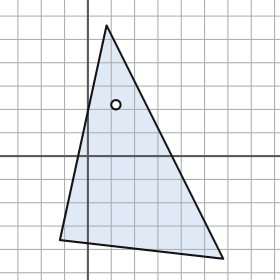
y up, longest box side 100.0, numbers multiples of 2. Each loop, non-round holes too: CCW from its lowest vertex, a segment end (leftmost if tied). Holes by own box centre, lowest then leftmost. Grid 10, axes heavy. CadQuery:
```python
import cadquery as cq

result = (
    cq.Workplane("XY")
    .moveTo(58.0, -44.0)
    .lineTo(8.0, 56.0)
    .lineTo(-12.0, -36.0)
    .close()
    .moveTo(12.0, 22.0)
    .circle(2.0)
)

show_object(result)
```